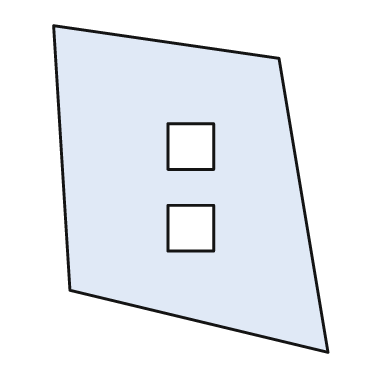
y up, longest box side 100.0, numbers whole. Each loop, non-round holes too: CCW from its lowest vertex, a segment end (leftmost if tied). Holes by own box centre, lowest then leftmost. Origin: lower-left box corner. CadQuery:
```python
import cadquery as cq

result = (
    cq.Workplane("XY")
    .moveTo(84.0, 0.0)
    .lineTo(69.0, 90.0)
    .lineTo(0.0, 100.0)
    .lineTo(5.0, 19.0)
    .close()
    .moveTo(35.0, 31.0)
    .lineTo(49.0, 31.0)
    .lineTo(49.0, 45.0)
    .lineTo(35.0, 45.0)
    .close()
    .moveTo(35.0, 56.0)
    .lineTo(49.0, 56.0)
    .lineTo(49.0, 70.0)
    .lineTo(35.0, 70.0)
    .close()
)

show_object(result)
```